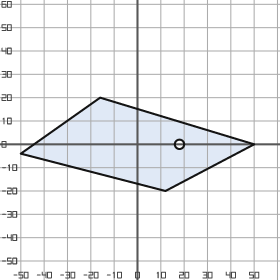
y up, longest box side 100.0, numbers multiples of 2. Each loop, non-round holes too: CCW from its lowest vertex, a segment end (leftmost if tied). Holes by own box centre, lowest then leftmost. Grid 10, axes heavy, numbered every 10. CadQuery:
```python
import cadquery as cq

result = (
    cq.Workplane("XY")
    .moveTo(12.0, -20.0)
    .lineTo(50.0, 0.0)
    .lineTo(-16.0, 20.0)
    .lineTo(-50.0, -4.0)
    .close()
    .moveTo(18.0, 0.0)
    .circle(2.0)
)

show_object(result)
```